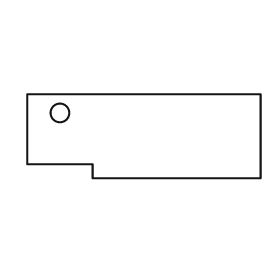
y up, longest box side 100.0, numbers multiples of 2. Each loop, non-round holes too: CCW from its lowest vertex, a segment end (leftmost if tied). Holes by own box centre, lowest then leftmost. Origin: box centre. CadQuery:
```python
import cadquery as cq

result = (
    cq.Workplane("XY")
    .moveTo(-22.0, -18.0)
    .lineTo(50.0, -18.0)
    .lineTo(50.0, 18.0)
    .lineTo(-50.0, 18.0)
    .lineTo(-50.0, -12.0)
    .lineTo(-22.0, -12.0)
    .close()
    .moveTo(-36.0, 10.0)
    .circle(4.0)
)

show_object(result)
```